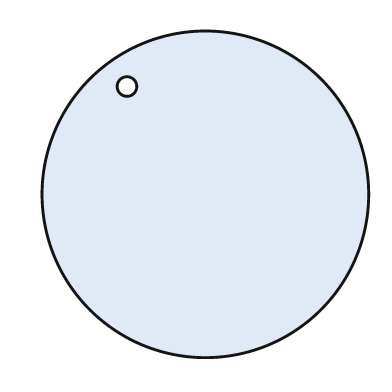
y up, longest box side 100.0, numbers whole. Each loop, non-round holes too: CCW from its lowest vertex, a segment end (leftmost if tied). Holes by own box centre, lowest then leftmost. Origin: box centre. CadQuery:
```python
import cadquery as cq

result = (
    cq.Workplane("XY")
    .moveTo(0.0, 0.0)
    .circle(50.0)
    .moveTo(-24.0, 33.0)
    .circle(3.0)
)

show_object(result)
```